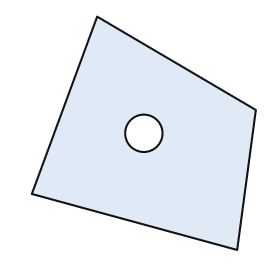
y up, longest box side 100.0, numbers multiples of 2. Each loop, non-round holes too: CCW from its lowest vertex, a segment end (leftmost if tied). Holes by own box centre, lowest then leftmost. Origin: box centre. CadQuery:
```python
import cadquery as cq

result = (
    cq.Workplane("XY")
    .moveTo(40.0, -50.0)
    .lineTo(48.0, 10.0)
    .lineTo(-20.0, 50.0)
    .lineTo(-48.0, -26.0)
    .close()
    .moveTo(0.0, 0.0)
    .circle(8.0)
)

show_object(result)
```